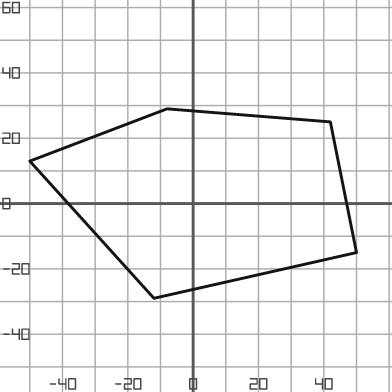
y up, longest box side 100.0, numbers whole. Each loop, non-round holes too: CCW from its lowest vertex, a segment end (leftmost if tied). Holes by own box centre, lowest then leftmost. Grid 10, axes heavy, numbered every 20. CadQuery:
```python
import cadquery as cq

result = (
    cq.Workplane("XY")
    .moveTo(-12.0, -29.0)
    .lineTo(50.0, -15.0)
    .lineTo(42.0, 25.0)
    .lineTo(-8.0, 29.0)
    .lineTo(-50.0, 13.0)
    .close()
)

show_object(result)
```